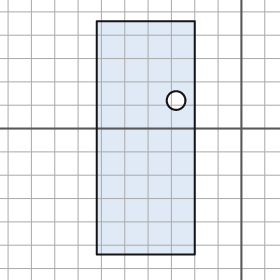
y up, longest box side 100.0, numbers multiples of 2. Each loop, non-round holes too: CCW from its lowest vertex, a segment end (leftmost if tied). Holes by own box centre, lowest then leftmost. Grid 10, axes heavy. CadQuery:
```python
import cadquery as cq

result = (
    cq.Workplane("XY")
    .moveTo(-62.0, -54.0)
    .lineTo(-20.0, -54.0)
    .lineTo(-20.0, 46.0)
    .lineTo(-62.0, 46.0)
    .close()
    .moveTo(-28.0, 12.0)
    .circle(4.0)
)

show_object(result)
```